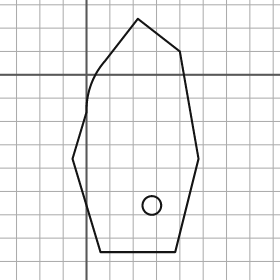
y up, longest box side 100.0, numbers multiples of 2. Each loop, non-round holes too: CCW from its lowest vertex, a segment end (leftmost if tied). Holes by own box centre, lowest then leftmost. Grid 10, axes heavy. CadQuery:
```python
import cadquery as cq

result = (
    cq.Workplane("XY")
    .moveTo(6.0, -76.0)
    .lineTo(38.0, -76.0)
    .lineTo(48.0, -36.0)
    .lineTo(40.0, 10.0)
    .lineTo(22.0, 24.0)
    .lineTo(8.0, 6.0)
    .threePointArc((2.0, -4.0), (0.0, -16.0))
    .lineTo(-6.0, -36.0)
    .close()
    .moveTo(28.0, -56.0)
    .circle(4.0)
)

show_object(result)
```